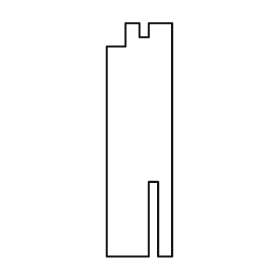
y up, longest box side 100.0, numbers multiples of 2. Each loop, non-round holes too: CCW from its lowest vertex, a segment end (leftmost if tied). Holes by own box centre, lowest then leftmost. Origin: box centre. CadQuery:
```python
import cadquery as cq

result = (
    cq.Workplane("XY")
    .moveTo(-14.0, -50.0)
    .lineTo(4.0, -50.0)
    .lineTo(4.0, -18.0)
    .lineTo(8.0, -18.0)
    .lineTo(8.0, -50.0)
    .lineTo(14.0, -50.0)
    .lineTo(14.0, 50.0)
    .lineTo(4.0, 50.0)
    .lineTo(4.0, 44.0)
    .lineTo(0.0, 44.0)
    .lineTo(0.0, 50.0)
    .lineTo(-6.0, 50.0)
    .lineTo(-6.0, 40.0)
    .lineTo(-14.0, 40.0)
    .close()
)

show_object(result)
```